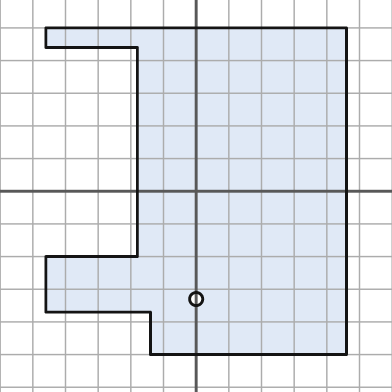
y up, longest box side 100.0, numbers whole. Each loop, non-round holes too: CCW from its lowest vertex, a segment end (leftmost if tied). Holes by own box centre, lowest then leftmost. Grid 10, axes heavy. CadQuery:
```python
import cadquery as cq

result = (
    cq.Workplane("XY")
    .moveTo(-14.0, -50.0)
    .lineTo(46.0, -50.0)
    .lineTo(46.0, 50.0)
    .lineTo(-46.0, 50.0)
    .lineTo(-46.0, 44.0)
    .lineTo(-18.0, 44.0)
    .lineTo(-18.0, -20.0)
    .lineTo(-46.0, -20.0)
    .lineTo(-46.0, -37.0)
    .lineTo(-14.0, -37.0)
    .close()
    .moveTo(0.0, -33.0)
    .circle(2.0)
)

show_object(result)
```